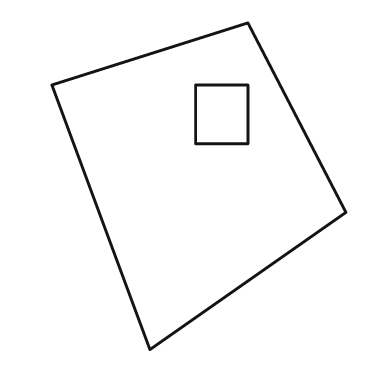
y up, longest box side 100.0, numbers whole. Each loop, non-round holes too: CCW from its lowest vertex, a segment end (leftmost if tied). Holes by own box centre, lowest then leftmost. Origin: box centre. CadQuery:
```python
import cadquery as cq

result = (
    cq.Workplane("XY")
    .moveTo(-15.0, -50.0)
    .lineTo(45.0, -8.0)
    .lineTo(15.0, 50.0)
    .lineTo(-45.0, 31.0)
    .close()
    .moveTo(-1.0, 13.0)
    .lineTo(15.0, 13.0)
    .lineTo(15.0, 31.0)
    .lineTo(-1.0, 31.0)
    .close()
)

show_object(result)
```